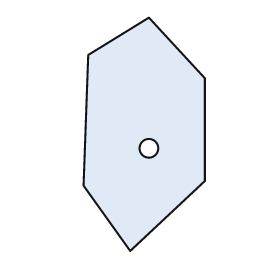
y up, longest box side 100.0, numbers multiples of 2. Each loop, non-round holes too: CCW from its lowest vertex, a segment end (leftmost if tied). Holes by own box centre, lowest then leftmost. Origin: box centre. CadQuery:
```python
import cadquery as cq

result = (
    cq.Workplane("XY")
    .moveTo(-6.0, -50.0)
    .lineTo(26.0, -20.0)
    .lineTo(26.0, 24.0)
    .lineTo(2.0, 50.0)
    .lineTo(-24.0, 34.0)
    .lineTo(-26.0, -22.0)
    .close()
    .moveTo(2.0, -6.0)
    .circle(4.0)
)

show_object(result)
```